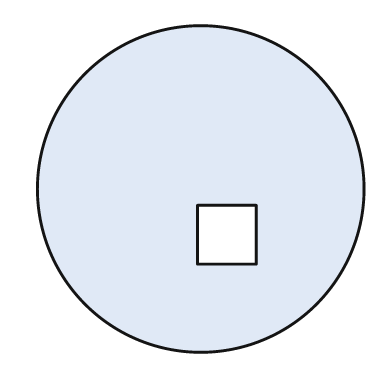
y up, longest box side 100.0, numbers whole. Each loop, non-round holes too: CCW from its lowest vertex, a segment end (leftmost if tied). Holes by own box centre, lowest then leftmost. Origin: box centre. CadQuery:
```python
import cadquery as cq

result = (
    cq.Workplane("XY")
    .moveTo(0.0, 0.0)
    .circle(50.0)
    .moveTo(-1.0, -23.0)
    .lineTo(17.0, -23.0)
    .lineTo(17.0, -5.0)
    .lineTo(-1.0, -5.0)
    .close()
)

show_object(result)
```